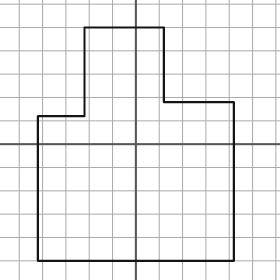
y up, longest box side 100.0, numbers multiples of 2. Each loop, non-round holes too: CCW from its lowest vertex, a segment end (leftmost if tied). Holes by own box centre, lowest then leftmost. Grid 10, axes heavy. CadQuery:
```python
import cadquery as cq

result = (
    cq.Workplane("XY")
    .moveTo(-42.0, -50.0)
    .lineTo(42.0, -50.0)
    .lineTo(42.0, 18.0)
    .lineTo(12.0, 18.0)
    .lineTo(12.0, 50.0)
    .lineTo(-22.0, 50.0)
    .lineTo(-22.0, 12.0)
    .lineTo(-42.0, 12.0)
    .close()
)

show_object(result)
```